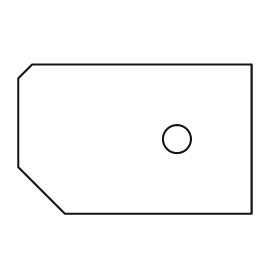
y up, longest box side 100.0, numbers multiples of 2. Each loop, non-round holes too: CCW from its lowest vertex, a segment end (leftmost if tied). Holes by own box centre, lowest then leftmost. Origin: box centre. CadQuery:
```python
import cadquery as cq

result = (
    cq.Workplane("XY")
    .moveTo(-30.0, -32.0)
    .lineTo(50.0, -32.0)
    .lineTo(50.0, 32.0)
    .lineTo(-44.0, 32.0)
    .lineTo(-50.0, 26.0)
    .lineTo(-50.0, -12.0)
    .close()
    .moveTo(18.0, 0.0)
    .circle(6.0)
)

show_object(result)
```